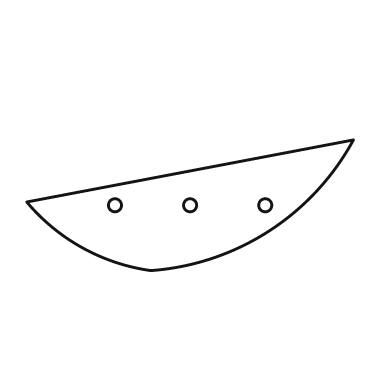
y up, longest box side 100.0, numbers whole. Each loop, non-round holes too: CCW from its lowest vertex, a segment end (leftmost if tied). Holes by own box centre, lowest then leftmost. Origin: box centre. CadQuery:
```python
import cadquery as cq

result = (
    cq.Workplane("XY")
    .moveTo(-12.0, -20.0)
    .threePointArc((24.0, -8.0), (50.0, 20.0))
    .lineTo(-50.0, 1.0)
    .threePointArc((-33.0, -13.0), (-12.0, -20.0))
    .close()
    .moveTo(-23.0, 0.0)
    .circle(2.0)
    .moveTo(0.0, 0.0)
    .circle(2.0)
    .moveTo(23.0, 0.0)
    .circle(2.0)
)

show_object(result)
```